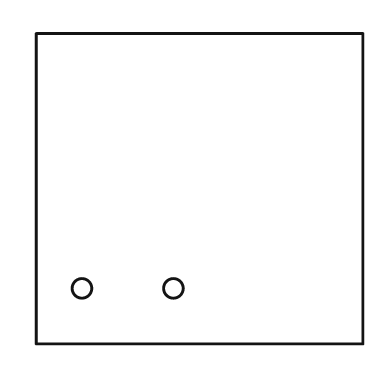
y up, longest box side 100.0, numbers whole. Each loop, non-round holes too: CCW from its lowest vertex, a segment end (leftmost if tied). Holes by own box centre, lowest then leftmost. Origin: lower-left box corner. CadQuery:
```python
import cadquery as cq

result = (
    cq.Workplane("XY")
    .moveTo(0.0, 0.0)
    .lineTo(100.0, 0.0)
    .lineTo(100.0, 95.0)
    .lineTo(0.0, 95.0)
    .close()
    .moveTo(14.0, 17.0)
    .circle(3.0)
    .moveTo(42.0, 17.0)
    .circle(3.0)
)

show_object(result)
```